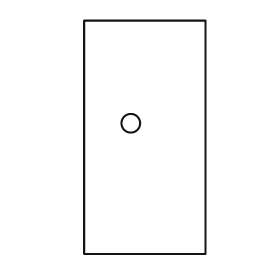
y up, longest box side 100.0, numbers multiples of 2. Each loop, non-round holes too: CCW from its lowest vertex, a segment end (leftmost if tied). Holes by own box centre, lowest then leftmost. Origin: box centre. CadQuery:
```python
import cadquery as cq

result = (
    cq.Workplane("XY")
    .moveTo(-26.0, -50.0)
    .lineTo(26.0, -50.0)
    .lineTo(26.0, 50.0)
    .lineTo(-26.0, 50.0)
    .close()
    .moveTo(-6.0, 6.0)
    .circle(4.0)
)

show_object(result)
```